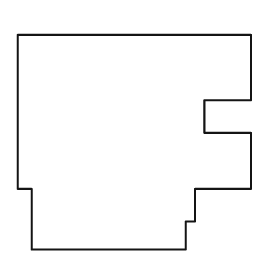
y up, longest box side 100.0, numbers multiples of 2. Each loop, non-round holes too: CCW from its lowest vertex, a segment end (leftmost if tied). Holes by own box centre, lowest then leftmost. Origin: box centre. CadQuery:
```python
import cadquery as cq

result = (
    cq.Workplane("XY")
    .moveTo(-44.0, -46.0)
    .lineTo(22.0, -46.0)
    .lineTo(22.0, -34.0)
    .lineTo(26.0, -34.0)
    .lineTo(26.0, -20.0)
    .lineTo(50.0, -20.0)
    .lineTo(50.0, 4.0)
    .lineTo(30.0, 4.0)
    .lineTo(30.0, 18.0)
    .lineTo(50.0, 18.0)
    .lineTo(50.0, 46.0)
    .lineTo(-50.0, 46.0)
    .lineTo(-50.0, -20.0)
    .lineTo(-44.0, -20.0)
    .close()
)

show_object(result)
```